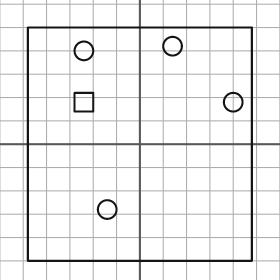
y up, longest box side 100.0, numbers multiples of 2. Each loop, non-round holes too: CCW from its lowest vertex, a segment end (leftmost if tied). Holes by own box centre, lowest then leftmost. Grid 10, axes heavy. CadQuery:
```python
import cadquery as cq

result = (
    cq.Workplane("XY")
    .moveTo(-48.0, -50.0)
    .lineTo(48.0, -50.0)
    .lineTo(48.0, 50.0)
    .lineTo(-48.0, 50.0)
    .close()
    .moveTo(-14.0, -28.0)
    .circle(4.0)
    .moveTo(-28.0, 14.0)
    .lineTo(-20.0, 14.0)
    .lineTo(-20.0, 22.0)
    .lineTo(-28.0, 22.0)
    .close()
    .moveTo(40.0, 18.0)
    .circle(4.0)
    .moveTo(-24.0, 40.0)
    .circle(4.0)
    .moveTo(14.0, 42.0)
    .circle(4.0)
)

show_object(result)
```